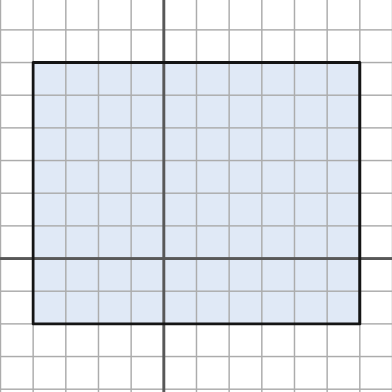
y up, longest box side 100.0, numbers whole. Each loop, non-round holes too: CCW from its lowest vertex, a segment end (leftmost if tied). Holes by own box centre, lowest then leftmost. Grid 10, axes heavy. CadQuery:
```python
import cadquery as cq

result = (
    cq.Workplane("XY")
    .moveTo(-40.0, -20.0)
    .lineTo(60.0, -20.0)
    .lineTo(60.0, 60.0)
    .lineTo(-40.0, 60.0)
    .close()
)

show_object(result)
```